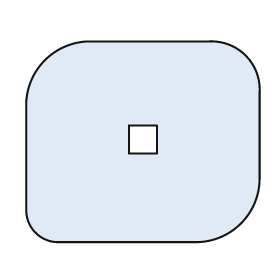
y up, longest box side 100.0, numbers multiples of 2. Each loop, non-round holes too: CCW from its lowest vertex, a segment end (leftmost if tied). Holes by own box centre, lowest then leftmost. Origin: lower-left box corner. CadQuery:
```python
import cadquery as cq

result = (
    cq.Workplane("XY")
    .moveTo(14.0, 0.0)
    .lineTo(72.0, 0.0)
    .threePointArc((92.0, 8.0), (100.0, 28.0))
    .lineTo(100.0, 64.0)
    .threePointArc((94.0, 80.0), (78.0, 86.0))
    .lineTo(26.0, 86.0)
    .threePointArc((8.0, 78.0), (0.0, 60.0))
    .lineTo(0.0, 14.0)
    .threePointArc((4.0, 4.0), (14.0, 0.0))
    .close()
    .moveTo(44.0, 38.0)
    .lineTo(56.0, 38.0)
    .lineTo(56.0, 50.0)
    .lineTo(44.0, 50.0)
    .close()
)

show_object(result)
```